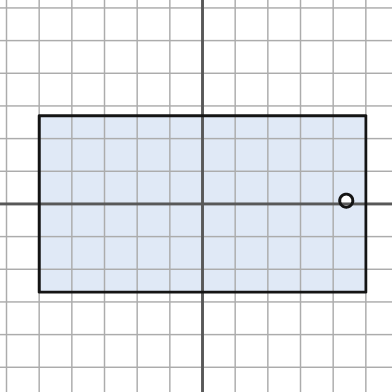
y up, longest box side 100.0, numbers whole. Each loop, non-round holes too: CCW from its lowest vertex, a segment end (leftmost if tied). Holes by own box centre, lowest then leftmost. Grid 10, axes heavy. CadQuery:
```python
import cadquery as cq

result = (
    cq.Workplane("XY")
    .moveTo(-50.0, -27.0)
    .lineTo(50.0, -27.0)
    .lineTo(50.0, 27.0)
    .lineTo(-50.0, 27.0)
    .close()
    .moveTo(44.0, 1.0)
    .circle(2.0)
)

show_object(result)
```